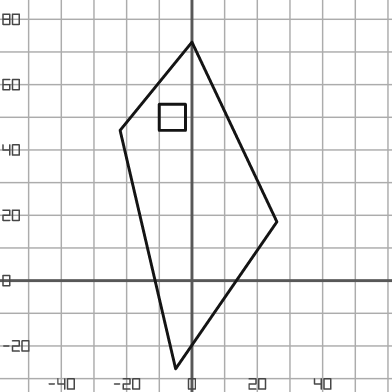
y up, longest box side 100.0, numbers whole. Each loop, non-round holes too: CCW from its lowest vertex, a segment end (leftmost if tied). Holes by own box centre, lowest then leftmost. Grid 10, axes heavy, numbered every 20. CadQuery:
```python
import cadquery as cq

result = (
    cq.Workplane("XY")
    .moveTo(-5.0, -27.0)
    .lineTo(26.0, 18.0)
    .lineTo(0.0, 73.0)
    .lineTo(-22.0, 46.0)
    .close()
    .moveTo(-10.0, 46.0)
    .lineTo(-2.0, 46.0)
    .lineTo(-2.0, 54.0)
    .lineTo(-10.0, 54.0)
    .close()
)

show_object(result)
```